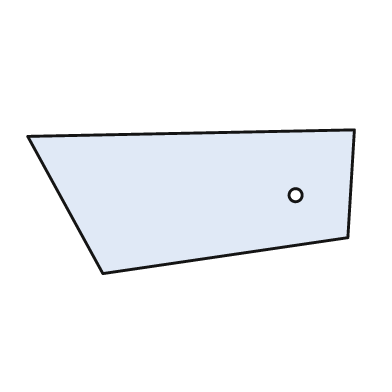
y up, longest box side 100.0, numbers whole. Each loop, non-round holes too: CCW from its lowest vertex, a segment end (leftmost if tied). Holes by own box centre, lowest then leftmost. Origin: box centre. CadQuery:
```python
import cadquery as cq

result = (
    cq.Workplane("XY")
    .moveTo(-27.0, -22.0)
    .lineTo(48.0, -11.0)
    .lineTo(50.0, 22.0)
    .lineTo(-50.0, 20.0)
    .close()
    .moveTo(32.0, 2.0)
    .circle(2.0)
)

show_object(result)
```